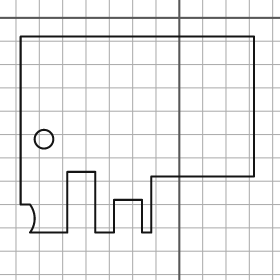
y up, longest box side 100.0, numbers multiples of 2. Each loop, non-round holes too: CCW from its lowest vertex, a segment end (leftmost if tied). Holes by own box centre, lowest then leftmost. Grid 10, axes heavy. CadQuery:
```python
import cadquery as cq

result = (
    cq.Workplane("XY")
    .moveTo(-64.0, -92.0)
    .lineTo(-48.0, -92.0)
    .lineTo(-48.0, -66.0)
    .lineTo(-36.0, -66.0)
    .lineTo(-36.0, -92.0)
    .lineTo(-28.0, -92.0)
    .lineTo(-28.0, -78.0)
    .lineTo(-16.0, -78.0)
    .lineTo(-16.0, -92.0)
    .lineTo(-12.0, -92.0)
    .lineTo(-12.0, -68.0)
    .lineTo(32.0, -68.0)
    .lineTo(32.0, -8.0)
    .lineTo(-68.0, -8.0)
    .lineTo(-68.0, -80.0)
    .lineTo(-64.0, -80.0)
    .threePointArc((-62.0, -86.0), (-64.0, -92.0))
    .close()
    .moveTo(-58.0, -52.0)
    .circle(4.0)
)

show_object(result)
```